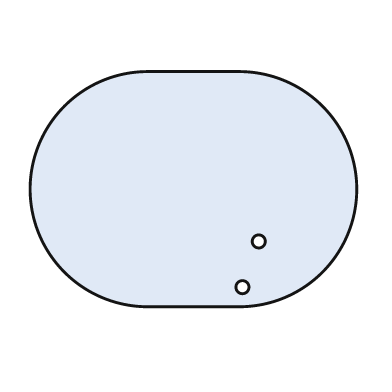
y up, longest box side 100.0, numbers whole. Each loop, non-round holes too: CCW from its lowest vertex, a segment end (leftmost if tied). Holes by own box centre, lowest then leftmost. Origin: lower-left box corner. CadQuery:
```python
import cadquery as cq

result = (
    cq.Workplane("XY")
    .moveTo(36.0, 0.0)
    .lineTo(64.0, 0.0)
    .threePointArc((100.0, 36.0), (64.0, 72.0))
    .lineTo(36.0, 72.0)
    .threePointArc((0.0, 36.0), (36.0, 0.0))
    .close()
    .moveTo(65.0, 6.0)
    .circle(2.0)
    .moveTo(70.0, 20.0)
    .circle(2.0)
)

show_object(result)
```